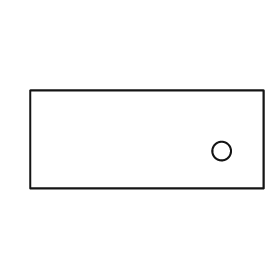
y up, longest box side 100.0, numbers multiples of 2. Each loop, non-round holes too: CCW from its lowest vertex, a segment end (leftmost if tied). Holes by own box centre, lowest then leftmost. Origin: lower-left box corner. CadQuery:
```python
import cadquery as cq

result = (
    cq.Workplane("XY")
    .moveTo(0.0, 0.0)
    .lineTo(100.0, 0.0)
    .lineTo(100.0, 42.0)
    .lineTo(0.0, 42.0)
    .close()
    .moveTo(82.0, 16.0)
    .circle(4.0)
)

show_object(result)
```